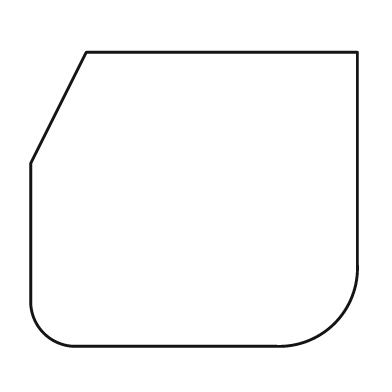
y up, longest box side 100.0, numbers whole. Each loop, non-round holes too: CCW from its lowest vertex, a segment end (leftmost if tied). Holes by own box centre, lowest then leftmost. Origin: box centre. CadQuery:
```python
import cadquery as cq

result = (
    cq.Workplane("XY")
    .moveTo(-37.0, -45.0)
    .lineTo(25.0, -45.0)
    .threePointArc((43.0, -38.0), (50.0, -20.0))
    .lineTo(50.0, 45.0)
    .lineTo(-33.0, 45.0)
    .lineTo(-50.0, 11.0)
    .lineTo(-50.0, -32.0)
    .threePointArc((-46.0, -41.0), (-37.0, -45.0))
    .close()
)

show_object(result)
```